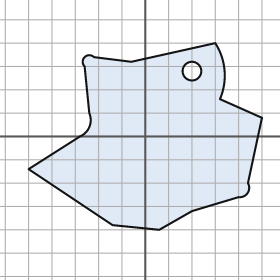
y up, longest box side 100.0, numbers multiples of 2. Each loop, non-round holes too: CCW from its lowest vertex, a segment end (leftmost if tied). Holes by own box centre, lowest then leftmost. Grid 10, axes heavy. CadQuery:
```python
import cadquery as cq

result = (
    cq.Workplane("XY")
    .moveTo(6.0, -40.0)
    .lineTo(20.0, -32.0)
    .lineTo(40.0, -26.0)
    .threePointArc((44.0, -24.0), (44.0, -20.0))
    .lineTo(50.0, 8.0)
    .lineTo(32.0, 16.0)
    .threePointArc((34.0, 28.0), (30.0, 40.0))
    .lineTo(-6.0, 32.0)
    .lineTo(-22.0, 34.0)
    .threePointArc((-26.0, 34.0), (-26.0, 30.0))
    .lineTo(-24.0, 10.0)
    .threePointArc((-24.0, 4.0), (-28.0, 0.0))
    .lineTo(-50.0, -14.0)
    .lineTo(-14.0, -38.0)
    .close()
    .moveTo(20.0, 28.0)
    .circle(4.0)
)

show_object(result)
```